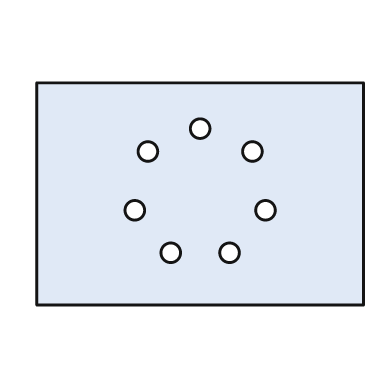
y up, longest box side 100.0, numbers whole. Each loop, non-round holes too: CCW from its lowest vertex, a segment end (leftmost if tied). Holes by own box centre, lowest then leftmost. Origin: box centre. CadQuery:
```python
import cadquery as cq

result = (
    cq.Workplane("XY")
    .moveTo(-50.0, -34.0)
    .lineTo(50.0, -34.0)
    .lineTo(50.0, 34.0)
    .lineTo(-50.0, 34.0)
    .close()
    .moveTo(-9.0, -18.0)
    .circle(3.0)
    .moveTo(9.0, -18.0)
    .circle(3.0)
    .moveTo(-20.0, -5.0)
    .circle(3.0)
    .moveTo(20.0, -5.0)
    .circle(3.0)
    .moveTo(-16.0, 13.0)
    .circle(3.0)
    .moveTo(16.0, 13.0)
    .circle(3.0)
    .moveTo(0.0, 20.0)
    .circle(3.0)
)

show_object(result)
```